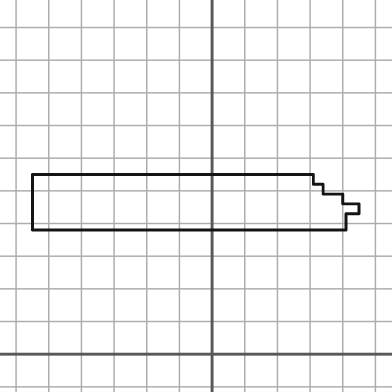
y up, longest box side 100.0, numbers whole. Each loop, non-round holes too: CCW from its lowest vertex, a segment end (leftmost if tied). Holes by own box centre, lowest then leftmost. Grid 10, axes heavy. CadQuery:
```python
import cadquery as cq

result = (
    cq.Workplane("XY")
    .moveTo(-55.0, 38.0)
    .lineTo(41.0, 38.0)
    .lineTo(41.0, 43.0)
    .lineTo(45.0, 43.0)
    .lineTo(45.0, 46.0)
    .lineTo(40.0, 46.0)
    .lineTo(40.0, 49.0)
    .lineTo(34.0, 49.0)
    .lineTo(34.0, 52.0)
    .lineTo(31.0, 52.0)
    .lineTo(31.0, 55.0)
    .lineTo(-55.0, 55.0)
    .close()
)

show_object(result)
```